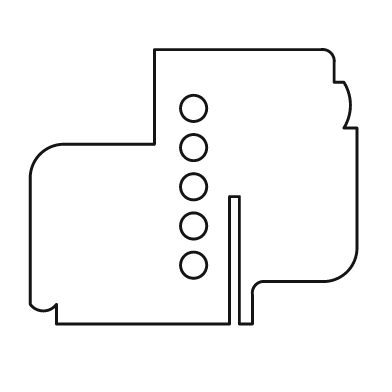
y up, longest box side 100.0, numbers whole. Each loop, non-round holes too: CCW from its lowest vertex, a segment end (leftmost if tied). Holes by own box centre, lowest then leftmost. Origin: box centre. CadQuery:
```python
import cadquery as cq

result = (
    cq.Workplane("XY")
    .moveTo(-42.0, -42.0)
    .lineTo(11.0, -42.0)
    .lineTo(11.0, -3.0)
    .lineTo(14.0, -3.0)
    .lineTo(14.0, -42.0)
    .lineTo(18.0, -42.0)
    .lineTo(18.0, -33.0)
    .threePointArc((19.0, -30.0), (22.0, -29.0))
    .lineTo(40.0, -29.0)
    .threePointArc((47.0, -26.0), (50.0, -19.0))
    .lineTo(50.0, 18.0)
    .lineTo(46.0, 18.0)
    .threePointArc((48.0, 25.0), (46.0, 32.0))
    .lineTo(43.0, 32.0)
    .lineTo(43.0, 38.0)
    .threePointArc((42.0, 41.0), (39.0, 42.0))
    .lineTo(-12.0, 42.0)
    .lineTo(-12.0, 13.0)
    .lineTo(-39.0, 13.0)
    .threePointArc((-47.0, 10.0), (-50.0, 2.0))
    .lineTo(-50.0, -36.0)
    .threePointArc((-46.0, -38.0), (-42.0, -36.0))
    .close()
    .moveTo(0.0, -24.0)
    .circle(4.0)
    .moveTo(0.0, -12.0)
    .circle(4.0)
    .moveTo(0.0, 0.0)
    .circle(4.0)
    .moveTo(0.0, 12.0)
    .circle(4.0)
    .moveTo(0.0, 24.0)
    .circle(4.0)
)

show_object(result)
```